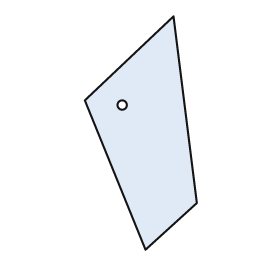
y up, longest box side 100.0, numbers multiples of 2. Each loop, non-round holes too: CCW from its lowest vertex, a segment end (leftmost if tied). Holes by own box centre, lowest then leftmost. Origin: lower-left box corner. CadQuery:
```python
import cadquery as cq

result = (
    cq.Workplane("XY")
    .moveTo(26.0, 0.0)
    .lineTo(48.0, 20.0)
    .lineTo(38.0, 100.0)
    .lineTo(0.0, 64.0)
    .close()
    .moveTo(16.0, 62.0)
    .circle(2.0)
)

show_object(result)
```